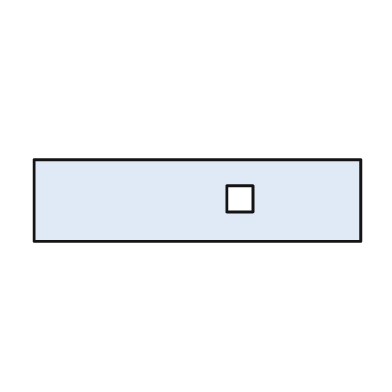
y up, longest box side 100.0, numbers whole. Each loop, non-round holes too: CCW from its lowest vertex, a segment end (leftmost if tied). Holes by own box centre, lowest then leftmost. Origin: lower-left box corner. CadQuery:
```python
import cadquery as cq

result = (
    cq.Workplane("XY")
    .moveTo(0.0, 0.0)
    .lineTo(100.0, 0.0)
    .lineTo(100.0, 25.0)
    .lineTo(0.0, 25.0)
    .close()
    .moveTo(59.0, 9.0)
    .lineTo(67.0, 9.0)
    .lineTo(67.0, 17.0)
    .lineTo(59.0, 17.0)
    .close()
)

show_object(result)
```